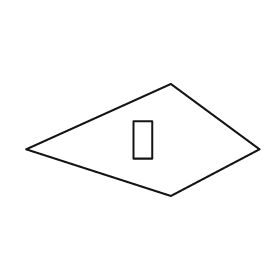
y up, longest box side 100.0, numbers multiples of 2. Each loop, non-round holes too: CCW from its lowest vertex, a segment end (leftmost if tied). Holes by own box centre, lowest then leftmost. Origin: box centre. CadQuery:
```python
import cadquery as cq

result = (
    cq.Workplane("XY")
    .moveTo(12.0, -24.0)
    .lineTo(50.0, -4.0)
    .lineTo(12.0, 24.0)
    .lineTo(-50.0, -4.0)
    .close()
    .moveTo(-4.0, -8.0)
    .lineTo(4.0, -8.0)
    .lineTo(4.0, 8.0)
    .lineTo(-4.0, 8.0)
    .close()
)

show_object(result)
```